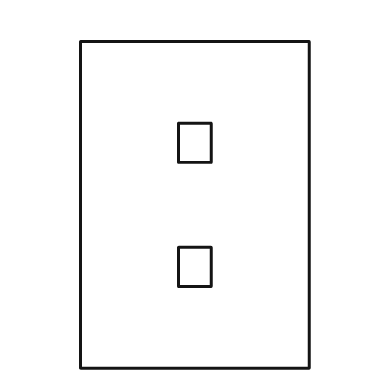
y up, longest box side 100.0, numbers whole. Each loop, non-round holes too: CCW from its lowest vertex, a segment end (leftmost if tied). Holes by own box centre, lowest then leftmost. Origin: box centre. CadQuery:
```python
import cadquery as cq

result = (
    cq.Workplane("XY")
    .moveTo(-35.0, -50.0)
    .lineTo(35.0, -50.0)
    .lineTo(35.0, 50.0)
    .lineTo(-35.0, 50.0)
    .close()
    .moveTo(-5.0, -25.0)
    .lineTo(5.0, -25.0)
    .lineTo(5.0, -13.0)
    .lineTo(-5.0, -13.0)
    .close()
    .moveTo(-5.0, 13.0)
    .lineTo(5.0, 13.0)
    .lineTo(5.0, 25.0)
    .lineTo(-5.0, 25.0)
    .close()
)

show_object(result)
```